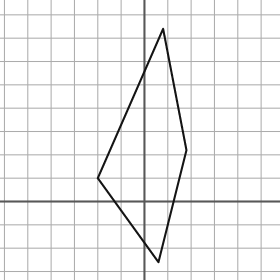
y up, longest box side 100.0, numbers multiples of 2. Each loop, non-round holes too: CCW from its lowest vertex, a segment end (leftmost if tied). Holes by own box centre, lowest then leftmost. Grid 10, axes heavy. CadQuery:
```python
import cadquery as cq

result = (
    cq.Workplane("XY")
    .moveTo(6.0, -26.0)
    .lineTo(18.0, 22.0)
    .lineTo(8.0, 74.0)
    .lineTo(-20.0, 10.0)
    .close()
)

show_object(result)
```